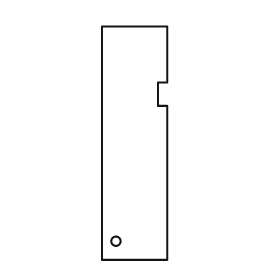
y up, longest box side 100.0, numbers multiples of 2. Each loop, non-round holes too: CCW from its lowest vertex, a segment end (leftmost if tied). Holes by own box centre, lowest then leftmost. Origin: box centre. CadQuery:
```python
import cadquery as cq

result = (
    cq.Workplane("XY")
    .moveTo(-14.0, -50.0)
    .lineTo(14.0, -50.0)
    .lineTo(14.0, 16.0)
    .lineTo(10.0, 16.0)
    .lineTo(10.0, 26.0)
    .lineTo(14.0, 26.0)
    .lineTo(14.0, 50.0)
    .lineTo(-14.0, 50.0)
    .close()
    .moveTo(-8.0, -42.0)
    .circle(2.0)
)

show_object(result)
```